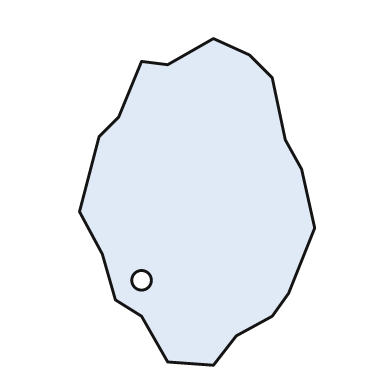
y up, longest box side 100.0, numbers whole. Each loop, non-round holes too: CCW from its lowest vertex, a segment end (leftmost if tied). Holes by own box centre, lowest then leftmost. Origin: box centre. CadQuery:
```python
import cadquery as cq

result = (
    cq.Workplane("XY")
    .moveTo(5.0, -50.0)
    .lineTo(12.0, -41.0)
    .lineTo(23.0, -35.0)
    .lineTo(28.0, -28.0)
    .lineTo(36.0, -8.0)
    .lineTo(32.0, 10.0)
    .lineTo(27.0, 19.0)
    .lineTo(23.0, 38.0)
    .lineTo(16.0, 45.0)
    .lineTo(5.0, 50.0)
    .lineTo(-9.0, 42.0)
    .lineTo(-17.0, 43.0)
    .lineTo(-24.0, 26.0)
    .lineTo(-30.0, 20.0)
    .lineTo(-36.0, -3.0)
    .lineTo(-29.0, -16.0)
    .lineTo(-25.0, -30.0)
    .lineTo(-17.0, -35.0)
    .lineTo(-9.0, -49.0)
    .close()
    .moveTo(-17.0, -24.0)
    .circle(3.0)
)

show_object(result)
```